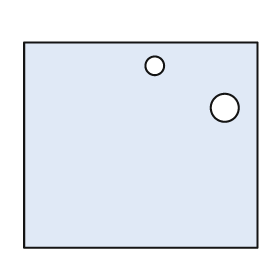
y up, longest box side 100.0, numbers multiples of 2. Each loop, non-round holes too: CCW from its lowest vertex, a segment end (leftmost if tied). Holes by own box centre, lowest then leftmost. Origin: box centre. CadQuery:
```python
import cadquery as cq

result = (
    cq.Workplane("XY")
    .moveTo(-50.0, -44.0)
    .lineTo(50.0, -44.0)
    .lineTo(50.0, 44.0)
    .lineTo(-50.0, 44.0)
    .close()
    .moveTo(36.0, 16.0)
    .circle(6.0)
    .moveTo(6.0, 34.0)
    .circle(4.0)
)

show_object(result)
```